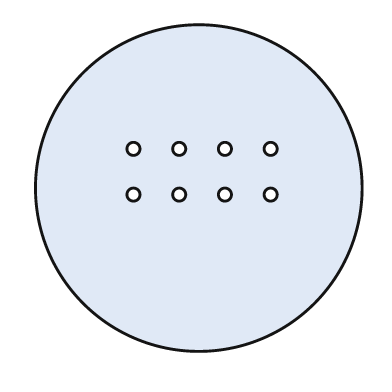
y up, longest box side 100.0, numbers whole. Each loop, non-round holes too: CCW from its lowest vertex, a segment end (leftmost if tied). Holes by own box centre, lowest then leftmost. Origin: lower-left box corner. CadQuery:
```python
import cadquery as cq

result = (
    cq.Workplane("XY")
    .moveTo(50.0, 50.0)
    .circle(50.0)
    .moveTo(30.0, 48.0)
    .circle(2.0)
    .moveTo(44.0, 48.0)
    .circle(2.0)
    .moveTo(58.0, 48.0)
    .circle(2.0)
    .moveTo(72.0, 48.0)
    .circle(2.0)
    .moveTo(30.0, 62.0)
    .circle(2.0)
    .moveTo(44.0, 62.0)
    .circle(2.0)
    .moveTo(58.0, 62.0)
    .circle(2.0)
    .moveTo(72.0, 62.0)
    .circle(2.0)
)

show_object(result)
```